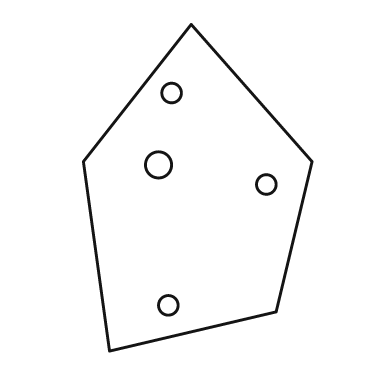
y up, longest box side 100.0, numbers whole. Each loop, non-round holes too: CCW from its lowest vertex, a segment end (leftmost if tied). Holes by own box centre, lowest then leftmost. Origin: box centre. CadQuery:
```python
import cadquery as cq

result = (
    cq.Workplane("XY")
    .moveTo(-27.0, -50.0)
    .lineTo(24.0, -38.0)
    .lineTo(35.0, 8.0)
    .lineTo(-2.0, 50.0)
    .lineTo(-35.0, 8.0)
    .close()
    .moveTo(-9.0, -36.0)
    .circle(3.0)
    .moveTo(21.0, 1.0)
    .circle(3.0)
    .moveTo(-12.0, 7.0)
    .circle(4.0)
    .moveTo(-8.0, 29.0)
    .circle(3.0)
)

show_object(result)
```